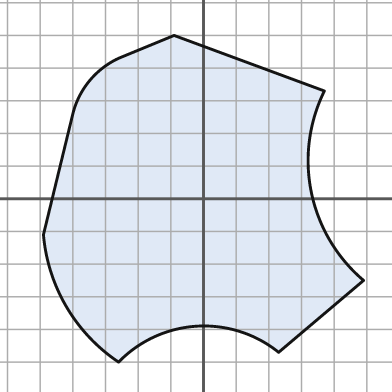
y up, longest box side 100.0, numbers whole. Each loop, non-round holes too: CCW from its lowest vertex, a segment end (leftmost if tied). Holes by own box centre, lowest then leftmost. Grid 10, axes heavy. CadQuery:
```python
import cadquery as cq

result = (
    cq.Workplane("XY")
    .moveTo(-26.0, -50.0)
    .threePointArc((-2.0, -39.0), (23.0, -47.0))
    .lineTo(49.0, -25.0)
    .threePointArc((33.0, 2.0), (37.0, 33.0))
    .lineTo(-9.0, 50.0)
    .lineTo(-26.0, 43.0)
    .threePointArc((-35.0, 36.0), (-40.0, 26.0))
    .lineTo(-49.0, -11.0)
    .threePointArc((-42.0, -33.0), (-26.0, -50.0))
    .close()
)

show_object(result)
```